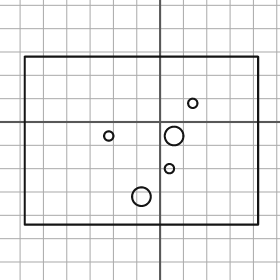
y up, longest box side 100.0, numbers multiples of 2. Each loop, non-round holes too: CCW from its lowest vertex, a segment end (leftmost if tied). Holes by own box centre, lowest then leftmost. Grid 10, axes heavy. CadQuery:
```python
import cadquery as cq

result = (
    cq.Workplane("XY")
    .moveTo(-58.0, -44.0)
    .lineTo(42.0, -44.0)
    .lineTo(42.0, 28.0)
    .lineTo(-58.0, 28.0)
    .close()
    .moveTo(-8.0, -32.0)
    .circle(4.0)
    .moveTo(4.0, -20.0)
    .circle(2.0)
    .moveTo(-22.0, -6.0)
    .circle(2.0)
    .moveTo(6.0, -6.0)
    .circle(4.0)
    .moveTo(14.0, 8.0)
    .circle(2.0)
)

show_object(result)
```